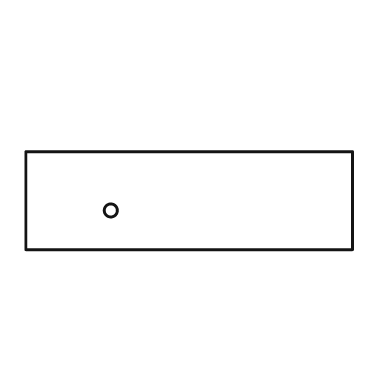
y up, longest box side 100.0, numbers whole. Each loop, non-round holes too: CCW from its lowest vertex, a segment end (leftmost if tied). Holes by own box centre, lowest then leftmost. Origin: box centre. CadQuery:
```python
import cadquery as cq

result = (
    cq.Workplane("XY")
    .moveTo(-50.0, -15.0)
    .lineTo(50.0, -15.0)
    .lineTo(50.0, 15.0)
    .lineTo(-50.0, 15.0)
    .close()
    .moveTo(-24.0, -3.0)
    .circle(2.0)
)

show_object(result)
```